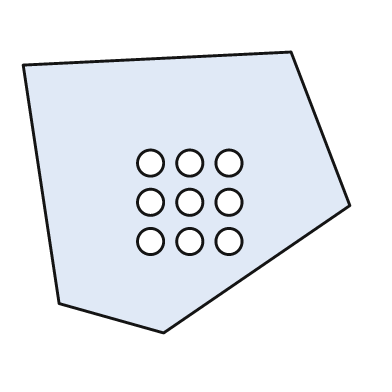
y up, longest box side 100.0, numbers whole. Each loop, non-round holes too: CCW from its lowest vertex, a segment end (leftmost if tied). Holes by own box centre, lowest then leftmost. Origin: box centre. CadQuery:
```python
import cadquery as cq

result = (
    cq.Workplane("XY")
    .moveTo(-7.0, -43.0)
    .lineTo(50.0, -4.0)
    .lineTo(32.0, 43.0)
    .lineTo(-50.0, 39.0)
    .lineTo(-39.0, -34.0)
    .close()
    .moveTo(-11.0, -15.0)
    .circle(4.0)
    .moveTo(1.0, -15.0)
    .circle(4.0)
    .moveTo(13.0, -15.0)
    .circle(4.0)
    .moveTo(-11.0, -3.0)
    .circle(4.0)
    .moveTo(1.0, -3.0)
    .circle(4.0)
    .moveTo(13.0, -3.0)
    .circle(4.0)
    .moveTo(-11.0, 9.0)
    .circle(4.0)
    .moveTo(1.0, 9.0)
    .circle(4.0)
    .moveTo(13.0, 9.0)
    .circle(4.0)
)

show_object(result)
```